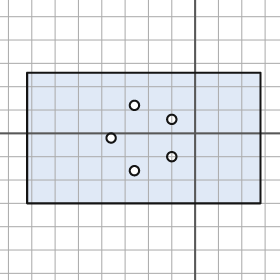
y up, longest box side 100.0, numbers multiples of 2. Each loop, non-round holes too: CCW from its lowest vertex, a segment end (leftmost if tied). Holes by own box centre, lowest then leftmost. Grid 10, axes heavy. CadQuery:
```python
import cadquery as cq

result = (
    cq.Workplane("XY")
    .moveTo(-72.0, -30.0)
    .lineTo(28.0, -30.0)
    .lineTo(28.0, 26.0)
    .lineTo(-72.0, 26.0)
    .close()
    .moveTo(-26.0, -16.0)
    .circle(2.0)
    .moveTo(-10.0, -10.0)
    .circle(2.0)
    .moveTo(-36.0, -2.0)
    .circle(2.0)
    .moveTo(-10.0, 6.0)
    .circle(2.0)
    .moveTo(-26.0, 12.0)
    .circle(2.0)
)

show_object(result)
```